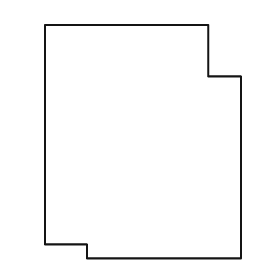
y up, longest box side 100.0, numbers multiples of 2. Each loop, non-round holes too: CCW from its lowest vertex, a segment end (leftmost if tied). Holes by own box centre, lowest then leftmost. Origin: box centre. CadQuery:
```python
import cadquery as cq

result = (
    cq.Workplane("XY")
    .moveTo(-24.0, -50.0)
    .lineTo(42.0, -50.0)
    .lineTo(42.0, 28.0)
    .lineTo(28.0, 28.0)
    .lineTo(28.0, 50.0)
    .lineTo(-42.0, 50.0)
    .lineTo(-42.0, -44.0)
    .lineTo(-24.0, -44.0)
    .close()
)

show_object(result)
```